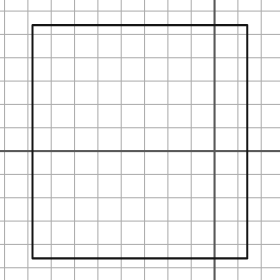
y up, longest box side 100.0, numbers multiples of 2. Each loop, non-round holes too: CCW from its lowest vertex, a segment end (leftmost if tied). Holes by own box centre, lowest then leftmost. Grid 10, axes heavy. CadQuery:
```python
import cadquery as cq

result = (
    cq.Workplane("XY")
    .moveTo(-78.0, -46.0)
    .lineTo(14.0, -46.0)
    .lineTo(14.0, 54.0)
    .lineTo(-78.0, 54.0)
    .close()
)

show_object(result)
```